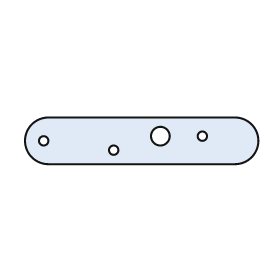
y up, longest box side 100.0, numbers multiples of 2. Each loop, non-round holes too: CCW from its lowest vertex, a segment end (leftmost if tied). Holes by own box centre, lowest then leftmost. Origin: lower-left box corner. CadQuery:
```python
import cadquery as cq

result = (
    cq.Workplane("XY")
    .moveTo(10.0, 0.0)
    .lineTo(90.0, 0.0)
    .threePointArc((100.0, 10.0), (90.0, 20.0))
    .lineTo(10.0, 20.0)
    .threePointArc((0.0, 10.0), (10.0, 0.0))
    .close()
    .moveTo(38.0, 6.0)
    .circle(2.0)
    .moveTo(8.0, 10.0)
    .circle(2.0)
    .moveTo(58.0, 12.0)
    .circle(4.0)
    .moveTo(76.0, 12.0)
    .circle(2.0)
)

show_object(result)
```